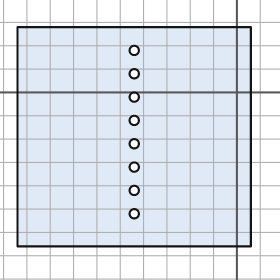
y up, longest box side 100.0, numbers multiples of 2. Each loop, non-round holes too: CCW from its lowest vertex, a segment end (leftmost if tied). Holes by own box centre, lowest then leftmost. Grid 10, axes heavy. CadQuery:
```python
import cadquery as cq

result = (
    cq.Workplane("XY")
    .moveTo(-94.0, -66.0)
    .lineTo(6.0, -66.0)
    .lineTo(6.0, 28.0)
    .lineTo(-94.0, 28.0)
    .close()
    .moveTo(-44.0, -52.0)
    .circle(2.0)
    .moveTo(-44.0, -42.0)
    .circle(2.0)
    .moveTo(-44.0, -32.0)
    .circle(2.0)
    .moveTo(-44.0, -22.0)
    .circle(2.0)
    .moveTo(-44.0, -12.0)
    .circle(2.0)
    .moveTo(-44.0, -2.0)
    .circle(2.0)
    .moveTo(-44.0, 8.0)
    .circle(2.0)
    .moveTo(-44.0, 18.0)
    .circle(2.0)
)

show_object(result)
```